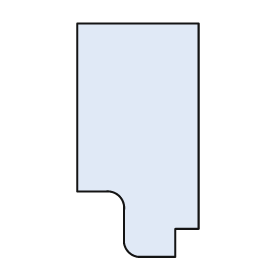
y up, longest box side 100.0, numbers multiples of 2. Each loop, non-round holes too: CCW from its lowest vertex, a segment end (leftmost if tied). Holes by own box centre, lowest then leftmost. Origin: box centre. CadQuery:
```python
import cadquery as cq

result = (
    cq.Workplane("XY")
    .moveTo(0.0, -50.0)
    .lineTo(16.0, -50.0)
    .lineTo(16.0, -38.0)
    .lineTo(26.0, -38.0)
    .lineTo(26.0, 50.0)
    .lineTo(-26.0, 50.0)
    .lineTo(-26.0, -22.0)
    .lineTo(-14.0, -22.0)
    .threePointArc((-8.0, -24.0), (-6.0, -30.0))
    .lineTo(-6.0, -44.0)
    .threePointArc((-4.0, -48.0), (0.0, -50.0))
    .close()
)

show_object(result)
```